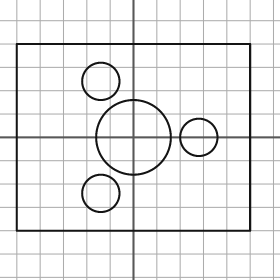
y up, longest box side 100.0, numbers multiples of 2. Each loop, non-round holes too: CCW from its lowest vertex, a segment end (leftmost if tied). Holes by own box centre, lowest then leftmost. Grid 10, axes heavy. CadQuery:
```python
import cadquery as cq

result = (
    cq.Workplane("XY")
    .moveTo(-50.0, -40.0)
    .lineTo(50.0, -40.0)
    .lineTo(50.0, 40.0)
    .lineTo(-50.0, 40.0)
    .close()
    .moveTo(-14.0, -24.0)
    .circle(8.0)
    .moveTo(0.0, 0.0)
    .circle(16.0)
    .moveTo(28.0, 0.0)
    .circle(8.0)
    .moveTo(-14.0, 24.0)
    .circle(8.0)
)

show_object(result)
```